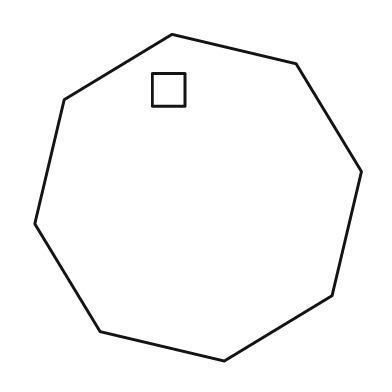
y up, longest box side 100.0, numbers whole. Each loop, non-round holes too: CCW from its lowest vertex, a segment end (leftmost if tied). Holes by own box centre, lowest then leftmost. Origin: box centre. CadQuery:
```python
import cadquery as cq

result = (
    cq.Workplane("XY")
    .moveTo(8.0, -50.0)
    .lineTo(41.0, -30.0)
    .lineTo(50.0, 8.0)
    .lineTo(30.0, 41.0)
    .lineTo(-8.0, 50.0)
    .lineTo(-41.0, 30.0)
    .lineTo(-50.0, -8.0)
    .lineTo(-30.0, -41.0)
    .close()
    .moveTo(-14.0, 28.0)
    .lineTo(-4.0, 28.0)
    .lineTo(-4.0, 38.0)
    .lineTo(-14.0, 38.0)
    .close()
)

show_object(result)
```